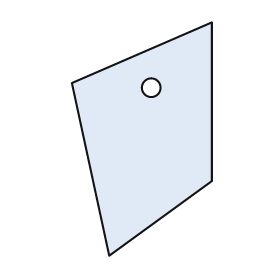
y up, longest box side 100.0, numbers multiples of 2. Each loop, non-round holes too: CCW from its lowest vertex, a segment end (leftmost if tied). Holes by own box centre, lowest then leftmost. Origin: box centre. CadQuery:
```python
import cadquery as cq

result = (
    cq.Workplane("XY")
    .moveTo(-14.0, -50.0)
    .lineTo(30.0, -18.0)
    .lineTo(30.0, 50.0)
    .lineTo(-30.0, 24.0)
    .close()
    .moveTo(4.0, 22.0)
    .circle(4.0)
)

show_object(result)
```